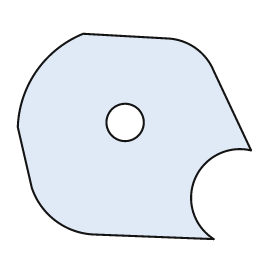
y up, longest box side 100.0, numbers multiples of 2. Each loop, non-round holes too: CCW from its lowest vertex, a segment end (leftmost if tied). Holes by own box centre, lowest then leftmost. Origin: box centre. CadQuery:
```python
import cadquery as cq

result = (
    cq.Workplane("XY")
    .moveTo(34.0, -44.0)
    .threePointArc((26.0, -18.0), (50.0, -6.0))
    .lineTo(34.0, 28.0)
    .threePointArc((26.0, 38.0), (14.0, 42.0))
    .lineTo(-22.0, 44.0)
    .threePointArc((-42.0, 28.0), (-50.0, 4.0))
    .lineTo(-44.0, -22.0)
    .threePointArc((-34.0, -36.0), (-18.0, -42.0))
    .close()
    .moveTo(-4.0, 6.0)
    .circle(8.0)
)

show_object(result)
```